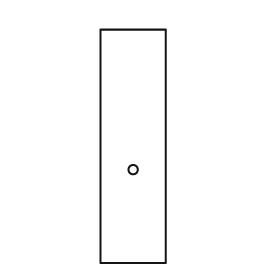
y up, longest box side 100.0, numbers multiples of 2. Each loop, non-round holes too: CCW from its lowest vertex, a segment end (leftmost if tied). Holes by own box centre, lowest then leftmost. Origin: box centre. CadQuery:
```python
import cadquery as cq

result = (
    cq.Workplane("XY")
    .moveTo(-14.0, -50.0)
    .lineTo(14.0, -50.0)
    .lineTo(14.0, 50.0)
    .lineTo(-14.0, 50.0)
    .close()
    .moveTo(0.0, -10.0)
    .circle(2.0)
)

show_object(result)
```